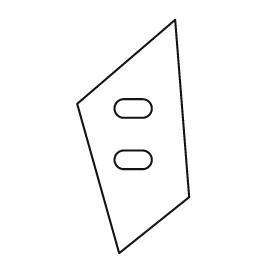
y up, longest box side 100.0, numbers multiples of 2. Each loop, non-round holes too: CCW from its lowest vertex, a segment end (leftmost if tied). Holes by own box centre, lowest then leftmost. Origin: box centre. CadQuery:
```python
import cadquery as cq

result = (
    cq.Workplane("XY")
    .moveTo(-6.0, -50.0)
    .lineTo(24.0, -26.0)
    .lineTo(18.0, 50.0)
    .lineTo(-24.0, 14.0)
    .close()
    .moveTo(-4.0, -14.0)
    .lineTo(4.0, -14.0)
    .threePointArc((8.0, -10.0), (4.0, -6.0))
    .lineTo(-4.0, -6.0)
    .threePointArc((-8.0, -10.0), (-4.0, -14.0))
    .close()
    .moveTo(-4.0, 8.0)
    .lineTo(4.0, 8.0)
    .threePointArc((8.0, 12.0), (4.0, 16.0))
    .lineTo(-4.0, 16.0)
    .threePointArc((-8.0, 12.0), (-4.0, 8.0))
    .close()
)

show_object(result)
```